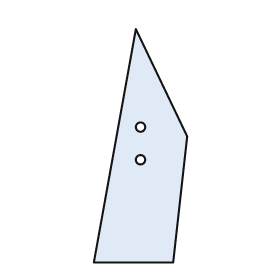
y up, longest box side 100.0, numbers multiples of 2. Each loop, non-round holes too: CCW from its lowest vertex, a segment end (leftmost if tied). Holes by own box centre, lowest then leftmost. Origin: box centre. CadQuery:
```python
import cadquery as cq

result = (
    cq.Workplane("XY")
    .moveTo(-20.0, -50.0)
    .lineTo(14.0, -50.0)
    .lineTo(20.0, 4.0)
    .lineTo(-2.0, 50.0)
    .close()
    .moveTo(0.0, -6.0)
    .circle(2.0)
    .moveTo(0.0, 8.0)
    .circle(2.0)
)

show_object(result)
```